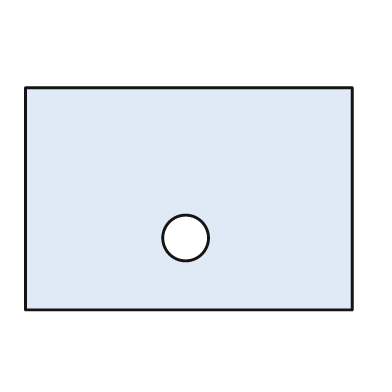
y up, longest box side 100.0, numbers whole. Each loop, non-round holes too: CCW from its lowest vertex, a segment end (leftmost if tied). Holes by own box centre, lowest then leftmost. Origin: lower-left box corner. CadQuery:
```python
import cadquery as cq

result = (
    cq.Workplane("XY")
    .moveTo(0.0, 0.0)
    .lineTo(100.0, 0.0)
    .lineTo(100.0, 68.0)
    .lineTo(0.0, 68.0)
    .close()
    .moveTo(49.0, 22.0)
    .circle(7.0)
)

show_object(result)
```